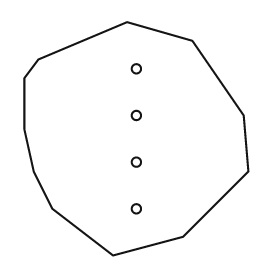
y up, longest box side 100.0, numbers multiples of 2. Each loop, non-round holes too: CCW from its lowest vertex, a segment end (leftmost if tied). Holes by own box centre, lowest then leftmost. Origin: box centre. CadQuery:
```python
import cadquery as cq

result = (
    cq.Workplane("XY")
    .moveTo(-10.0, -50.0)
    .lineTo(20.0, -42.0)
    .lineTo(48.0, -14.0)
    .lineTo(46.0, 10.0)
    .lineTo(24.0, 42.0)
    .lineTo(-4.0, 50.0)
    .lineTo(-42.0, 34.0)
    .lineTo(-48.0, 26.0)
    .lineTo(-48.0, 4.0)
    .lineTo(-44.0, -14.0)
    .lineTo(-36.0, -30.0)
    .close()
    .moveTo(0.0, -30.0)
    .circle(2.0)
    .moveTo(0.0, -10.0)
    .circle(2.0)
    .moveTo(0.0, 10.0)
    .circle(2.0)
    .moveTo(0.0, 30.0)
    .circle(2.0)
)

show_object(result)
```